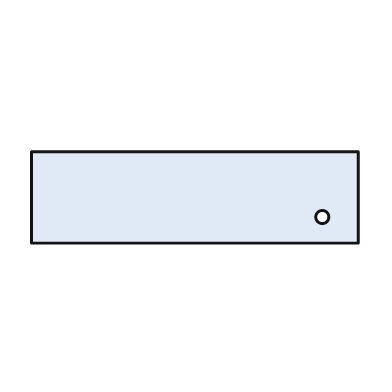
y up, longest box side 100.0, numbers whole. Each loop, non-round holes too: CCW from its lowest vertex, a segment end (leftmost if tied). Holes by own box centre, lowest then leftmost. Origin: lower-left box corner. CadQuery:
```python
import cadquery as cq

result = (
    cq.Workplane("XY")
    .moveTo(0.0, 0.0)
    .lineTo(100.0, 0.0)
    .lineTo(100.0, 28.0)
    .lineTo(0.0, 28.0)
    .close()
    .moveTo(89.0, 8.0)
    .circle(2.0)
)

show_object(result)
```